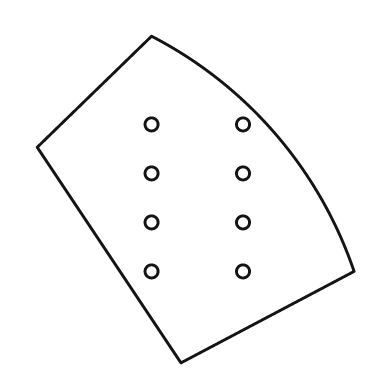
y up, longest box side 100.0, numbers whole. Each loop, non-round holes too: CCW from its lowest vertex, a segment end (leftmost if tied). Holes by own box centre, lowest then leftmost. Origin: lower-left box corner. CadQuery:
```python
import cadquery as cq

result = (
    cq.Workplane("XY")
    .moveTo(44.0, 0.0)
    .lineTo(97.0, 28.0)
    .threePointArc((73.0, 70.0), (35.0, 100.0))
    .lineTo(0.0, 66.0)
    .close()
    .moveTo(35.0, 28.0)
    .circle(2.0)
    .moveTo(63.0, 28.0)
    .circle(2.0)
    .moveTo(35.0, 43.0)
    .circle(2.0)
    .moveTo(63.0, 43.0)
    .circle(2.0)
    .moveTo(35.0, 58.0)
    .circle(2.0)
    .moveTo(63.0, 58.0)
    .circle(2.0)
    .moveTo(35.0, 73.0)
    .circle(2.0)
    .moveTo(63.0, 73.0)
    .circle(2.0)
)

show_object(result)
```